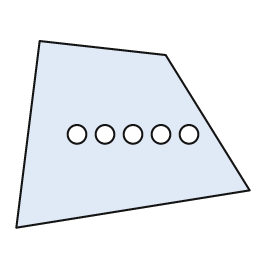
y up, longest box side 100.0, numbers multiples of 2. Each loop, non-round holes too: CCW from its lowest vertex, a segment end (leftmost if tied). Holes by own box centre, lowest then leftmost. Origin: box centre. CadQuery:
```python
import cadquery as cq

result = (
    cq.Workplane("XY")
    .moveTo(-50.0, -40.0)
    .lineTo(50.0, -24.0)
    .lineTo(14.0, 34.0)
    .lineTo(-40.0, 40.0)
    .close()
    .moveTo(-24.0, 0.0)
    .circle(4.0)
    .moveTo(-12.0, 0.0)
    .circle(4.0)
    .moveTo(0.0, 0.0)
    .circle(4.0)
    .moveTo(12.0, 0.0)
    .circle(4.0)
    .moveTo(24.0, 0.0)
    .circle(4.0)
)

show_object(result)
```